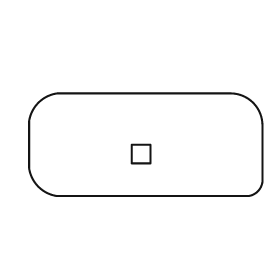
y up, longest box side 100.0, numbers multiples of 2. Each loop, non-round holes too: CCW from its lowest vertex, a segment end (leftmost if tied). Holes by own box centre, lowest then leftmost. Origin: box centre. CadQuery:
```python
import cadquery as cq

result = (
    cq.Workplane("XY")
    .moveTo(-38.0, -22.0)
    .lineTo(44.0, -22.0)
    .threePointArc((48.0, -20.0), (50.0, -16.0))
    .lineTo(50.0, 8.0)
    .threePointArc((46.0, 18.0), (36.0, 22.0))
    .lineTo(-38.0, 22.0)
    .threePointArc((-46.0, 18.0), (-50.0, 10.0))
    .lineTo(-50.0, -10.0)
    .threePointArc((-46.0, -18.0), (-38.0, -22.0))
    .close()
    .moveTo(-6.0, -8.0)
    .lineTo(2.0, -8.0)
    .lineTo(2.0, 0.0)
    .lineTo(-6.0, 0.0)
    .close()
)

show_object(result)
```